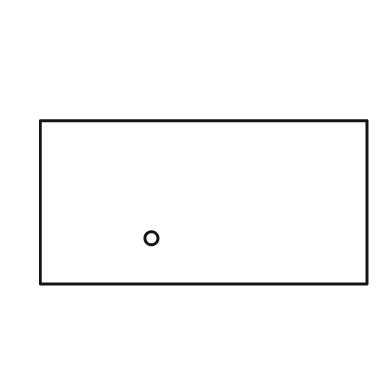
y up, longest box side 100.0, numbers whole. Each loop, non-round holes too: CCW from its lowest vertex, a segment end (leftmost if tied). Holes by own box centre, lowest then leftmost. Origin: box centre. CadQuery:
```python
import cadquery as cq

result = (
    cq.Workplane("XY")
    .moveTo(-50.0, -25.0)
    .lineTo(50.0, -25.0)
    .lineTo(50.0, 25.0)
    .lineTo(-50.0, 25.0)
    .close()
    .moveTo(-16.0, -11.0)
    .circle(2.0)
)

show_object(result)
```